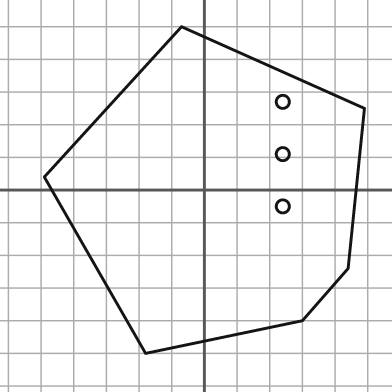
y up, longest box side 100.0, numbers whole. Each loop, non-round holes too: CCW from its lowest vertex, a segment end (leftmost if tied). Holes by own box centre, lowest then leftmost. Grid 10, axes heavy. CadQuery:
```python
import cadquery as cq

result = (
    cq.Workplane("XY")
    .moveTo(-18.0, -50.0)
    .lineTo(30.0, -40.0)
    .lineTo(44.0, -24.0)
    .lineTo(49.0, 25.0)
    .lineTo(-7.0, 50.0)
    .lineTo(-49.0, 4.0)
    .close()
    .moveTo(24.0, -5.0)
    .circle(2.0)
    .moveTo(24.0, 11.0)
    .circle(2.0)
    .moveTo(24.0, 27.0)
    .circle(2.0)
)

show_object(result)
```